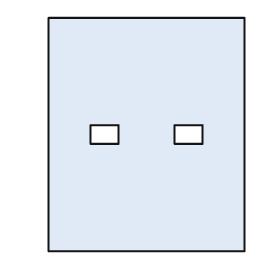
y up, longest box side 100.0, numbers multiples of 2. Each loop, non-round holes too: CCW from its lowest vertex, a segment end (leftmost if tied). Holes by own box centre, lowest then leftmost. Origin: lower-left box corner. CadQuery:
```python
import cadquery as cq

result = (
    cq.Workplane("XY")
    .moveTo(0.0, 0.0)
    .lineTo(84.0, 0.0)
    .lineTo(84.0, 100.0)
    .lineTo(0.0, 100.0)
    .close()
    .moveTo(18.0, 46.0)
    .lineTo(30.0, 46.0)
    .lineTo(30.0, 54.0)
    .lineTo(18.0, 54.0)
    .close()
    .moveTo(54.0, 46.0)
    .lineTo(66.0, 46.0)
    .lineTo(66.0, 54.0)
    .lineTo(54.0, 54.0)
    .close()
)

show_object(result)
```